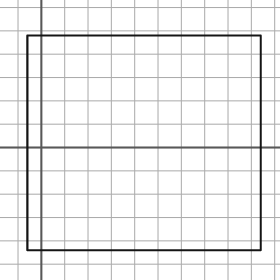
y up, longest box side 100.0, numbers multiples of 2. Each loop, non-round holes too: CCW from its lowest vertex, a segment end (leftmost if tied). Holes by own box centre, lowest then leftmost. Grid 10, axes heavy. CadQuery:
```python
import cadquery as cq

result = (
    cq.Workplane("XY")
    .moveTo(-6.0, -44.0)
    .lineTo(94.0, -44.0)
    .lineTo(94.0, 48.0)
    .lineTo(-6.0, 48.0)
    .close()
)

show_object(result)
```